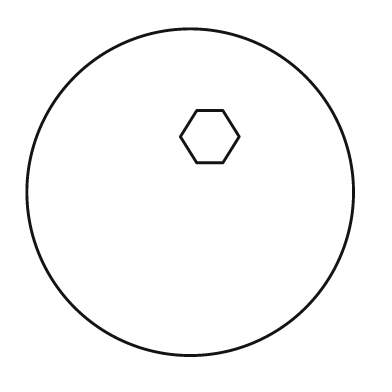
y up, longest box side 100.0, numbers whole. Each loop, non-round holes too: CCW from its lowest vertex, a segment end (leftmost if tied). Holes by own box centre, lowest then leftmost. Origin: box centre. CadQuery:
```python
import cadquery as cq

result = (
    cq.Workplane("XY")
    .moveTo(0.0, 0.0)
    .circle(50.0)
    .moveTo(2.0, 9.0)
    .lineTo(10.0, 9.0)
    .lineTo(15.0, 17.0)
    .lineTo(10.0, 25.0)
    .lineTo(2.0, 25.0)
    .lineTo(-3.0, 17.0)
    .close()
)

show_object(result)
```